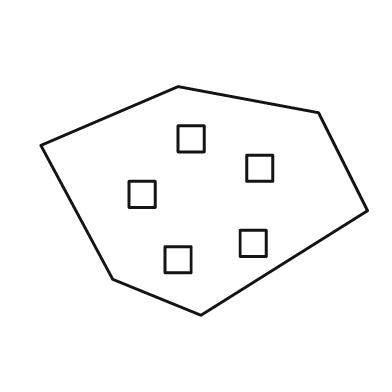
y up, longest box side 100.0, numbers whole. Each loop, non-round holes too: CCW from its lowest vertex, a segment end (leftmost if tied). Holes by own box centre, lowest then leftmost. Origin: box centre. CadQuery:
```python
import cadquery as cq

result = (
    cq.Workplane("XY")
    .moveTo(-1.0, -35.0)
    .lineTo(50.0, -3.0)
    .lineTo(35.0, 27.0)
    .lineTo(-8.0, 35.0)
    .lineTo(-50.0, 17.0)
    .lineTo(-28.0, -24.0)
    .close()
    .moveTo(-12.0, -22.0)
    .lineTo(-4.0, -22.0)
    .lineTo(-4.0, -14.0)
    .lineTo(-12.0, -14.0)
    .close()
    .moveTo(11.0, -17.0)
    .lineTo(19.0, -17.0)
    .lineTo(19.0, -9.0)
    .lineTo(11.0, -9.0)
    .close()
    .moveTo(-23.0, -2.0)
    .lineTo(-15.0, -2.0)
    .lineTo(-15.0, 6.0)
    .lineTo(-23.0, 6.0)
    .close()
    .moveTo(13.0, 6.0)
    .lineTo(21.0, 6.0)
    .lineTo(21.0, 14.0)
    .lineTo(13.0, 14.0)
    .close()
    .moveTo(-8.0, 15.0)
    .lineTo(0.0, 15.0)
    .lineTo(0.0, 23.0)
    .lineTo(-8.0, 23.0)
    .close()
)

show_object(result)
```